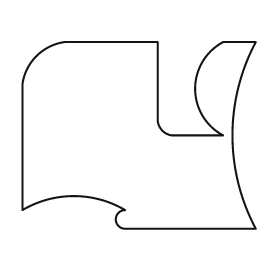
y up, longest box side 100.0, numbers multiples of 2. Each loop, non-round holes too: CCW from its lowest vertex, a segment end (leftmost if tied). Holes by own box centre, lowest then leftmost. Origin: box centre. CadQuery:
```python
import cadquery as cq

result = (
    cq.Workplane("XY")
    .moveTo(-6.0, -40.0)
    .lineTo(50.0, -40.0)
    .threePointArc((40.0, 0.0), (50.0, 40.0))
    .lineTo(36.0, 40.0)
    .threePointArc((24.0, 20.0), (36.0, 0.0))
    .lineTo(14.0, 0.0)
    .threePointArc((10.0, 2.0), (8.0, 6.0))
    .lineTo(8.0, 40.0)
    .lineTo(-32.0, 40.0)
    .threePointArc((-44.0, 34.0), (-50.0, 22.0))
    .lineTo(-50.0, -32.0)
    .threePointArc((-28.0, -26.0), (-6.0, -32.0))
    .threePointArc((-10.0, -36.0), (-6.0, -40.0))
    .close()
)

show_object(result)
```